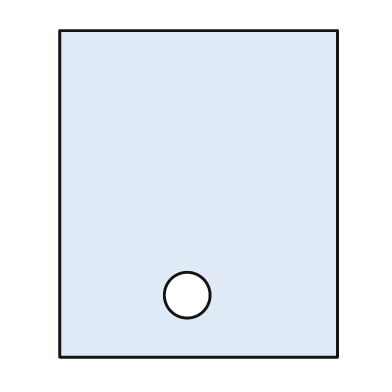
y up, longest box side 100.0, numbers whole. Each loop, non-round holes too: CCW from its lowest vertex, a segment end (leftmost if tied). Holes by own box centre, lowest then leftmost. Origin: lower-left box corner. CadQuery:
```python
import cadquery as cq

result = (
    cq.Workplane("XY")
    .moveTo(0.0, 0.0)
    .lineTo(85.0, 0.0)
    .lineTo(85.0, 100.0)
    .lineTo(0.0, 100.0)
    .close()
    .moveTo(39.0, 19.0)
    .circle(7.0)
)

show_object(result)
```